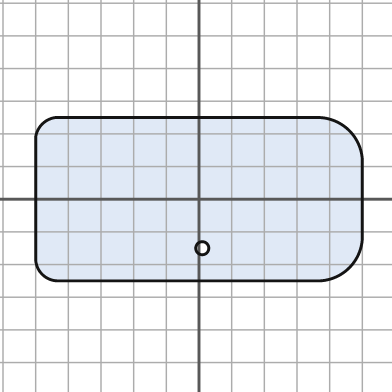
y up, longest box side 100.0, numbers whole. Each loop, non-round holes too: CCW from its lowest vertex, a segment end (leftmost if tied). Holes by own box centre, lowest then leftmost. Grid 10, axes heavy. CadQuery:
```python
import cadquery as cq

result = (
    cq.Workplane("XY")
    .moveTo(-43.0, -25.0)
    .lineTo(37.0, -25.0)
    .threePointArc((46.0, -21.0), (50.0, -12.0))
    .lineTo(50.0, 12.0)
    .threePointArc((46.0, 21.0), (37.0, 25.0))
    .lineTo(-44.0, 25.0)
    .threePointArc((-48.0, 23.0), (-50.0, 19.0))
    .lineTo(-50.0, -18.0)
    .threePointArc((-48.0, -23.0), (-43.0, -25.0))
    .close()
    .moveTo(1.0, -15.0)
    .circle(2.0)
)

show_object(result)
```